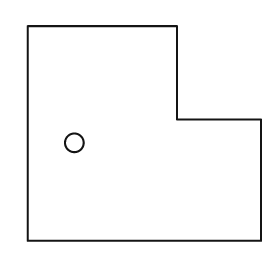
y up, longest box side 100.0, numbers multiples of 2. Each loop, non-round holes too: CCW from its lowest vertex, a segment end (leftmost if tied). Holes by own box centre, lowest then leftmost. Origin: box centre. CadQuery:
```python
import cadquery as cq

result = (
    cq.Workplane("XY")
    .moveTo(-50.0, -46.0)
    .lineTo(50.0, -46.0)
    .lineTo(50.0, 6.0)
    .lineTo(14.0, 6.0)
    .lineTo(14.0, 46.0)
    .lineTo(-50.0, 46.0)
    .close()
    .moveTo(-30.0, -4.0)
    .circle(4.0)
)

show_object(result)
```